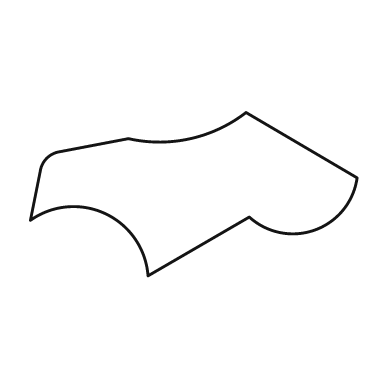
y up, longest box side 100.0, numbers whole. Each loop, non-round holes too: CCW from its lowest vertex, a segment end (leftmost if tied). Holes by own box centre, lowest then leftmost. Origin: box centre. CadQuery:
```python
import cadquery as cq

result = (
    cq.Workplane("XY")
    .moveTo(-14.0, -25.0)
    .lineTo(17.0, -7.0)
    .threePointArc((37.0, -11.0), (50.0, 5.0))
    .lineTo(16.0, 25.0)
    .threePointArc((-1.0, 17.0), (-20.0, 17.0))
    .lineTo(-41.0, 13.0)
    .threePointArc((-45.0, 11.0), (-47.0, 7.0))
    .lineTo(-50.0, -8.0)
    .threePointArc((-27.0, -6.0), (-14.0, -25.0))
    .close()
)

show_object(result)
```